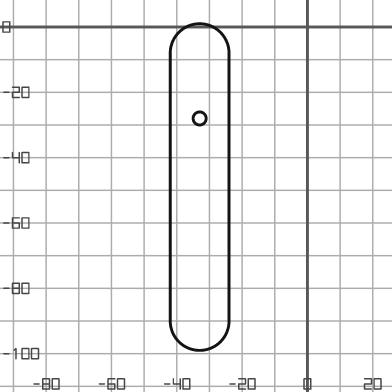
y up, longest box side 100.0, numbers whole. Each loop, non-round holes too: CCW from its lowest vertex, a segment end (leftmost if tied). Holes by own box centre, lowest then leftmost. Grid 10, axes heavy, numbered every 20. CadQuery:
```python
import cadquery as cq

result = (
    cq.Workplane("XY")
    .moveTo(-42.0, -90.0)
    .threePointArc((-33.0, -99.0), (-24.0, -90.0))
    .lineTo(-24.0, -8.0)
    .threePointArc((-33.0, 1.0), (-42.0, -8.0))
    .close()
    .moveTo(-33.0, -28.0)
    .circle(2.0)
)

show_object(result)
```